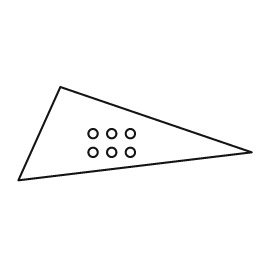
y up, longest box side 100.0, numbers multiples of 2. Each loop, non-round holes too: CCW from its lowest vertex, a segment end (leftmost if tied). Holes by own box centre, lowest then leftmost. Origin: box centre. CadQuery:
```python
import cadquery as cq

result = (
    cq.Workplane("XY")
    .moveTo(-50.0, -20.0)
    .lineTo(50.0, -8.0)
    .lineTo(-32.0, 20.0)
    .close()
    .moveTo(-18.0, -8.0)
    .circle(2.0)
    .moveTo(-10.0, -8.0)
    .circle(2.0)
    .moveTo(-2.0, -8.0)
    .circle(2.0)
    .moveTo(-18.0, 0.0)
    .circle(2.0)
    .moveTo(-10.0, 0.0)
    .circle(2.0)
    .moveTo(-2.0, 0.0)
    .circle(2.0)
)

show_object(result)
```